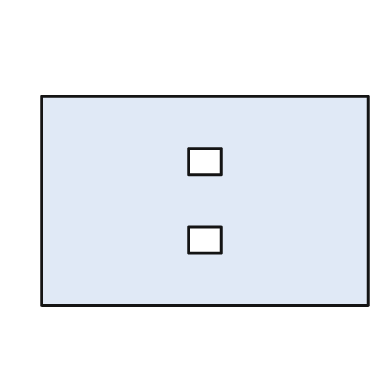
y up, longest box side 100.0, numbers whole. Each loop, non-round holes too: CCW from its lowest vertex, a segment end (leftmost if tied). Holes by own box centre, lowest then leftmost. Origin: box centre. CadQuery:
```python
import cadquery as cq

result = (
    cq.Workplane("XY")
    .moveTo(-50.0, -32.0)
    .lineTo(50.0, -32.0)
    .lineTo(50.0, 32.0)
    .lineTo(-50.0, 32.0)
    .close()
    .moveTo(-5.0, -16.0)
    .lineTo(5.0, -16.0)
    .lineTo(5.0, -8.0)
    .lineTo(-5.0, -8.0)
    .close()
    .moveTo(-5.0, 8.0)
    .lineTo(5.0, 8.0)
    .lineTo(5.0, 16.0)
    .lineTo(-5.0, 16.0)
    .close()
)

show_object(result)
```